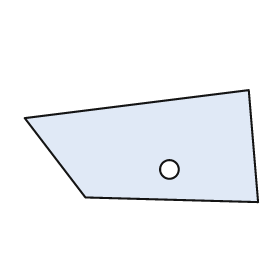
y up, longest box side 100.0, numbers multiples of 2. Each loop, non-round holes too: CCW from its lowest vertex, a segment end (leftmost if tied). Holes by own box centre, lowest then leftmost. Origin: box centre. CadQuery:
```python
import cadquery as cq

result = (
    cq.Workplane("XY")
    .moveTo(50.0, -24.0)
    .lineTo(46.0, 24.0)
    .lineTo(-50.0, 12.0)
    .lineTo(-24.0, -22.0)
    .close()
    .moveTo(12.0, -10.0)
    .circle(4.0)
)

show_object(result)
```